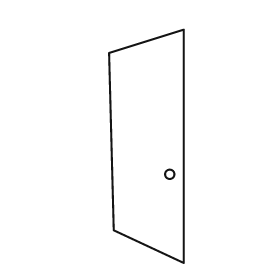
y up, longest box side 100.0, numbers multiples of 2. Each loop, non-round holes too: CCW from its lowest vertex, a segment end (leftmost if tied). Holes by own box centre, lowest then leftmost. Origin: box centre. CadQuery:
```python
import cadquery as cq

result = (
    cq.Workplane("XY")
    .moveTo(16.0, -50.0)
    .lineTo(16.0, 50.0)
    .lineTo(-16.0, 40.0)
    .lineTo(-14.0, -36.0)
    .close()
    .moveTo(10.0, -12.0)
    .circle(2.0)
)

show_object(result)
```